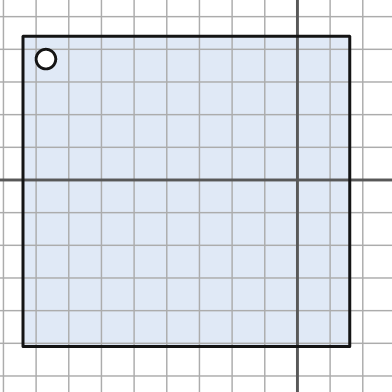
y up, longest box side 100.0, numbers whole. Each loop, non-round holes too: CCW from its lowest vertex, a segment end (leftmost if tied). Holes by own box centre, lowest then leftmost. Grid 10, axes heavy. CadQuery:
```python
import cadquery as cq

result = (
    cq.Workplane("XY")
    .moveTo(-84.0, -51.0)
    .lineTo(16.0, -51.0)
    .lineTo(16.0, 44.0)
    .lineTo(-84.0, 44.0)
    .close()
    .moveTo(-77.0, 37.0)
    .circle(3.0)
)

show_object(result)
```